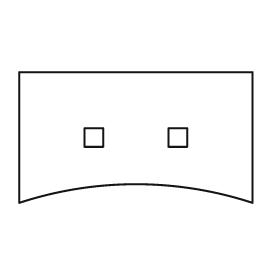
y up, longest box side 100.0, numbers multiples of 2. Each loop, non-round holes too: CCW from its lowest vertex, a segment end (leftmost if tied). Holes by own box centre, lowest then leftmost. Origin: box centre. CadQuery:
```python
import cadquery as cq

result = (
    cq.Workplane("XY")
    .moveTo(-50.0, -28.0)
    .threePointArc((0.0, -20.0), (50.0, -28.0))
    .lineTo(50.0, 28.0)
    .lineTo(-50.0, 28.0)
    .close()
    .moveTo(-22.0, -4.0)
    .lineTo(-14.0, -4.0)
    .lineTo(-14.0, 4.0)
    .lineTo(-22.0, 4.0)
    .close()
    .moveTo(14.0, -4.0)
    .lineTo(22.0, -4.0)
    .lineTo(22.0, 4.0)
    .lineTo(14.0, 4.0)
    .close()
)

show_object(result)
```